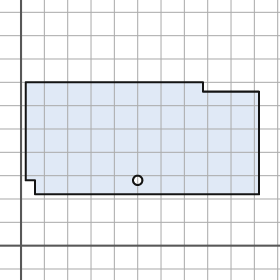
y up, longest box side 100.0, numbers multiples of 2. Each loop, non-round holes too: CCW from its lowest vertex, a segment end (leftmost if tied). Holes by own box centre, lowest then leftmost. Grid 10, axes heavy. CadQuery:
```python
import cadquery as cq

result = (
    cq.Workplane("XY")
    .moveTo(6.0, 22.0)
    .lineTo(102.0, 22.0)
    .lineTo(102.0, 66.0)
    .lineTo(78.0, 66.0)
    .lineTo(78.0, 70.0)
    .lineTo(2.0, 70.0)
    .lineTo(2.0, 28.0)
    .lineTo(6.0, 28.0)
    .close()
    .moveTo(50.0, 28.0)
    .circle(2.0)
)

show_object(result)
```